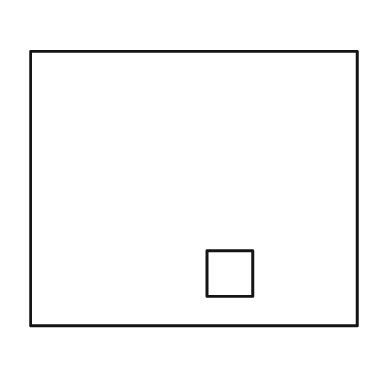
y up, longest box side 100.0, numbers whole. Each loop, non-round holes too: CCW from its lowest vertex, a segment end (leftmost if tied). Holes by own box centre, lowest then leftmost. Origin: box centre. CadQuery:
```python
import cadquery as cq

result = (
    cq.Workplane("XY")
    .moveTo(-50.0, -42.0)
    .lineTo(50.0, -42.0)
    .lineTo(50.0, 42.0)
    .lineTo(-50.0, 42.0)
    .close()
    .moveTo(4.0, -33.0)
    .lineTo(18.0, -33.0)
    .lineTo(18.0, -19.0)
    .lineTo(4.0, -19.0)
    .close()
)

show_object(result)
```